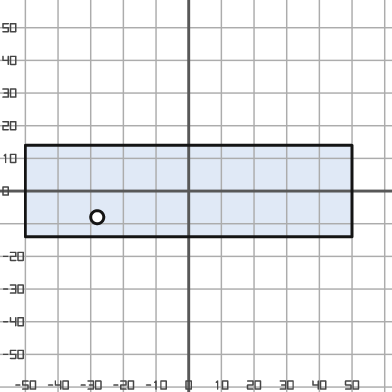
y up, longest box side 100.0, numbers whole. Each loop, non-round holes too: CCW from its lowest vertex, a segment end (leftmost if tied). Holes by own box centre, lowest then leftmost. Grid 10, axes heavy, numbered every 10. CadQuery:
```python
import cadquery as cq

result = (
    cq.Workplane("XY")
    .moveTo(-50.0, -14.0)
    .lineTo(50.0, -14.0)
    .lineTo(50.0, 14.0)
    .lineTo(-50.0, 14.0)
    .close()
    .moveTo(-28.0, -8.0)
    .circle(2.0)
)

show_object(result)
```